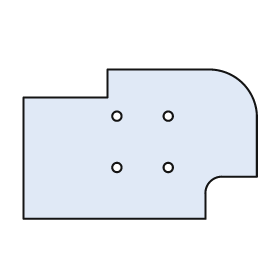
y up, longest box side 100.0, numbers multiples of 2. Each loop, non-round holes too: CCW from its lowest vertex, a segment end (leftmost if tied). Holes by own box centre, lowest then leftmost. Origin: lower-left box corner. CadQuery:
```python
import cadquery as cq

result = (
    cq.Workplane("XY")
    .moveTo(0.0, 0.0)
    .lineTo(78.0, 0.0)
    .lineTo(78.0, 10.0)
    .threePointArc((80.0, 16.0), (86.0, 18.0))
    .lineTo(100.0, 18.0)
    .lineTo(100.0, 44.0)
    .threePointArc((94.0, 58.0), (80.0, 64.0))
    .lineTo(36.0, 64.0)
    .lineTo(36.0, 52.0)
    .lineTo(0.0, 52.0)
    .close()
    .moveTo(40.0, 22.0)
    .circle(2.0)
    .moveTo(62.0, 22.0)
    .circle(2.0)
    .moveTo(40.0, 44.0)
    .circle(2.0)
    .moveTo(62.0, 44.0)
    .circle(2.0)
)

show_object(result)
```